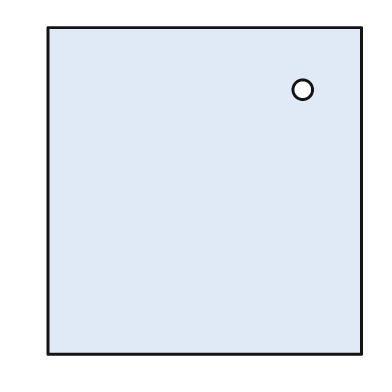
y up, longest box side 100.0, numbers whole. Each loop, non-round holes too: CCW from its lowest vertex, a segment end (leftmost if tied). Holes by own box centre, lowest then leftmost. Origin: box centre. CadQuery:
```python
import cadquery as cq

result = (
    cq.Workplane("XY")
    .moveTo(-48.0, -50.0)
    .lineTo(48.0, -50.0)
    .lineTo(48.0, 50.0)
    .lineTo(-48.0, 50.0)
    .close()
    .moveTo(30.0, 31.0)
    .circle(3.0)
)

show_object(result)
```